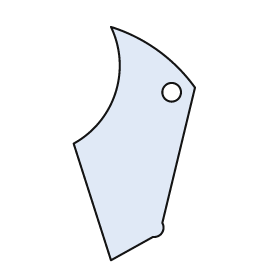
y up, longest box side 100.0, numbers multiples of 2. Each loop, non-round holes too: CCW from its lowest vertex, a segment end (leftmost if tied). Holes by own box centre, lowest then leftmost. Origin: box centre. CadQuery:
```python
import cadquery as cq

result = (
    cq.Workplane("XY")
    .moveTo(-10.0, -50.0)
    .lineTo(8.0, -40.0)
    .threePointArc((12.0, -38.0), (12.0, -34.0))
    .lineTo(26.0, 24.0)
    .threePointArc((10.0, 40.0), (-10.0, 50.0))
    .threePointArc((-8.0, 22.0), (-26.0, 0.0))
    .close()
    .moveTo(16.0, 22.0)
    .circle(4.0)
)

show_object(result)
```